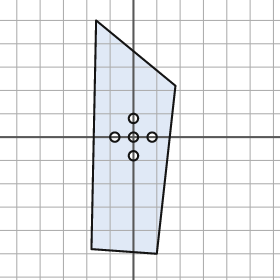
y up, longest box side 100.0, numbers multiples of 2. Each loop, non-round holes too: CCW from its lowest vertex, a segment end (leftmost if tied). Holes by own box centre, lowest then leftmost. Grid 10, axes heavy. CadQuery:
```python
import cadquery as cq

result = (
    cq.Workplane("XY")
    .moveTo(10.0, -50.0)
    .lineTo(18.0, 22.0)
    .lineTo(-16.0, 50.0)
    .lineTo(-18.0, -48.0)
    .close()
    .moveTo(0.0, -8.0)
    .circle(2.0)
    .moveTo(-8.0, 0.0)
    .circle(2.0)
    .moveTo(0.0, 0.0)
    .circle(2.0)
    .moveTo(8.0, 0.0)
    .circle(2.0)
    .moveTo(0.0, 8.0)
    .circle(2.0)
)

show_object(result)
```